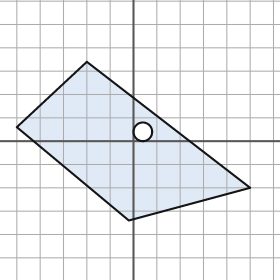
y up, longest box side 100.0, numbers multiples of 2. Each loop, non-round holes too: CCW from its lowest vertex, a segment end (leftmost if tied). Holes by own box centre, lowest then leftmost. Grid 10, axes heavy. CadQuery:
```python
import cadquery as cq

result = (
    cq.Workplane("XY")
    .moveTo(-2.0, -34.0)
    .lineTo(50.0, -20.0)
    .lineTo(-20.0, 34.0)
    .lineTo(-50.0, 6.0)
    .close()
    .moveTo(4.0, 4.0)
    .circle(4.0)
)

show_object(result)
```